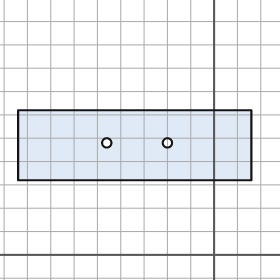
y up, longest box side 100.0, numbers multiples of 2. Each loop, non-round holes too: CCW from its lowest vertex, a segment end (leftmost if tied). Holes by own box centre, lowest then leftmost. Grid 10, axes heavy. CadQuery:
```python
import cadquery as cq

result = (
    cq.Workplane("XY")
    .moveTo(-84.0, 32.0)
    .lineTo(16.0, 32.0)
    .lineTo(16.0, 62.0)
    .lineTo(-84.0, 62.0)
    .close()
    .moveTo(-46.0, 48.0)
    .circle(2.0)
    .moveTo(-20.0, 48.0)
    .circle(2.0)
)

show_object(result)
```